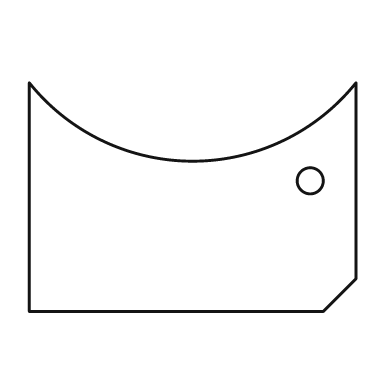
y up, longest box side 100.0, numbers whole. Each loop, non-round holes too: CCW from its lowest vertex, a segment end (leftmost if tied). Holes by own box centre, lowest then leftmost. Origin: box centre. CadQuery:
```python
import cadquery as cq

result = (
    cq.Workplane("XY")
    .moveTo(-50.0, -35.0)
    .lineTo(40.0, -35.0)
    .lineTo(50.0, -25.0)
    .lineTo(50.0, 35.0)
    .threePointArc((0.0, 11.0), (-50.0, 35.0))
    .close()
    .moveTo(36.0, 5.0)
    .circle(4.0)
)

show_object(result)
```